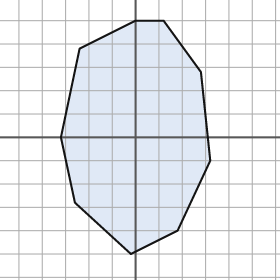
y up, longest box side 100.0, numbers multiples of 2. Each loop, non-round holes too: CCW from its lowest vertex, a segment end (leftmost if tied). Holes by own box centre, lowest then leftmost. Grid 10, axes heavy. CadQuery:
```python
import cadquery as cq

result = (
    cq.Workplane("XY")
    .moveTo(-2.0, -50.0)
    .lineTo(18.0, -40.0)
    .lineTo(32.0, -10.0)
    .lineTo(28.0, 28.0)
    .lineTo(12.0, 50.0)
    .lineTo(0.0, 50.0)
    .lineTo(-24.0, 38.0)
    .lineTo(-32.0, 0.0)
    .lineTo(-26.0, -28.0)
    .close()
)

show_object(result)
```